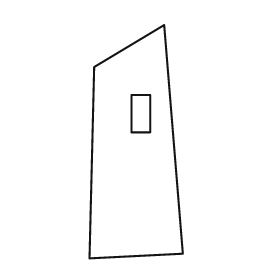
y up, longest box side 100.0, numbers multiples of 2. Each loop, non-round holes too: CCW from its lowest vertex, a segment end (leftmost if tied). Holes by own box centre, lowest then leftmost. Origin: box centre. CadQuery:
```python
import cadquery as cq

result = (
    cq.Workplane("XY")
    .moveTo(-20.0, -50.0)
    .lineTo(20.0, -48.0)
    .lineTo(12.0, 50.0)
    .lineTo(-18.0, 32.0)
    .close()
    .moveTo(-2.0, 4.0)
    .lineTo(6.0, 4.0)
    .lineTo(6.0, 20.0)
    .lineTo(-2.0, 20.0)
    .close()
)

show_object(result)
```